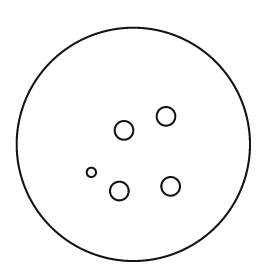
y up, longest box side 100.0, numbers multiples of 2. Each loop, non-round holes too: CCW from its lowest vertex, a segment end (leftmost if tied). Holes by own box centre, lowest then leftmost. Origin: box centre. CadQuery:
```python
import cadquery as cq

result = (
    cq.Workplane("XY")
    .moveTo(0.0, 0.0)
    .circle(50.0)
    .moveTo(-6.0, -20.0)
    .circle(4.0)
    .moveTo(16.0, -18.0)
    .circle(4.0)
    .moveTo(-18.0, -12.0)
    .circle(2.0)
    .moveTo(-4.0, 6.0)
    .circle(4.0)
    .moveTo(14.0, 12.0)
    .circle(4.0)
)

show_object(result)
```